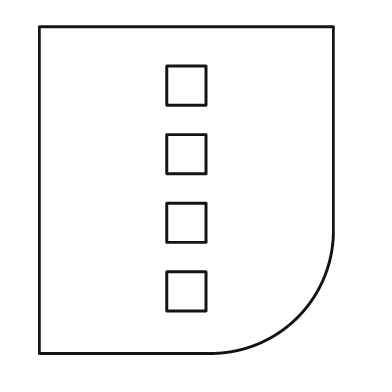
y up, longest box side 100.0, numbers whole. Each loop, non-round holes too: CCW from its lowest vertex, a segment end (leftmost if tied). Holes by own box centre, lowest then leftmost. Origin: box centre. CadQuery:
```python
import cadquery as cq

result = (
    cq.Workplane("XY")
    .moveTo(-45.0, -50.0)
    .lineTo(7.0, -50.0)
    .threePointArc((34.0, -39.0), (45.0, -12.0))
    .lineTo(45.0, 50.0)
    .lineTo(-45.0, 50.0)
    .close()
    .moveTo(-6.0, -37.0)
    .lineTo(6.0, -37.0)
    .lineTo(6.0, -25.0)
    .lineTo(-6.0, -25.0)
    .close()
    .moveTo(-6.0, -16.0)
    .lineTo(6.0, -16.0)
    .lineTo(6.0, -4.0)
    .lineTo(-6.0, -4.0)
    .close()
    .moveTo(-6.0, 5.0)
    .lineTo(6.0, 5.0)
    .lineTo(6.0, 17.0)
    .lineTo(-6.0, 17.0)
    .close()
    .moveTo(-6.0, 26.0)
    .lineTo(6.0, 26.0)
    .lineTo(6.0, 38.0)
    .lineTo(-6.0, 38.0)
    .close()
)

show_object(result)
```